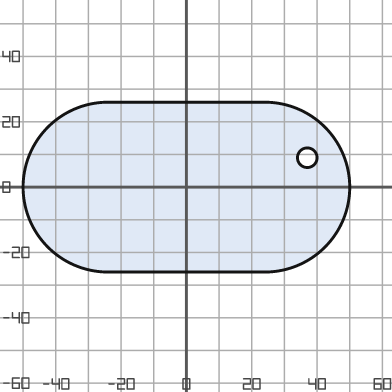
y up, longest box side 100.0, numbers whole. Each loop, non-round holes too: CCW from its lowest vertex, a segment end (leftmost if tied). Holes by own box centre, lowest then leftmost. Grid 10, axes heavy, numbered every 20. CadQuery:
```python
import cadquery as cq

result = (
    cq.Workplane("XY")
    .moveTo(-24.0, -26.0)
    .lineTo(24.0, -26.0)
    .threePointArc((50.0, 0.0), (24.0, 26.0))
    .lineTo(-24.0, 26.0)
    .threePointArc((-50.0, 0.0), (-24.0, -26.0))
    .close()
    .moveTo(37.0, 9.0)
    .circle(3.0)
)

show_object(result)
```